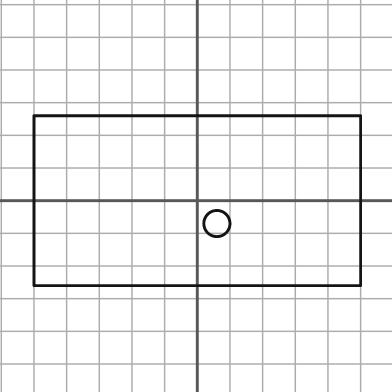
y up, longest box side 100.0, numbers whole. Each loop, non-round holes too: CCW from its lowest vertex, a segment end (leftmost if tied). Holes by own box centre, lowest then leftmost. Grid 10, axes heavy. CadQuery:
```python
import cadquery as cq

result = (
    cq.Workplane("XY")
    .moveTo(-50.0, -26.0)
    .lineTo(50.0, -26.0)
    .lineTo(50.0, 26.0)
    .lineTo(-50.0, 26.0)
    .close()
    .moveTo(6.0, -7.0)
    .circle(4.0)
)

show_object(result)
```